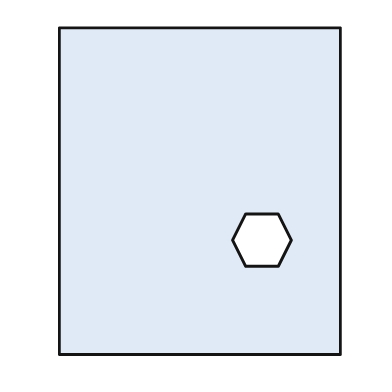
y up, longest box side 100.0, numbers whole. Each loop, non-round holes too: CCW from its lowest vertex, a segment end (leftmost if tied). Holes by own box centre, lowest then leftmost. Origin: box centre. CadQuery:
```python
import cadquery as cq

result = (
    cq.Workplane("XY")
    .moveTo(-43.0, -50.0)
    .lineTo(43.0, -50.0)
    .lineTo(43.0, 50.0)
    .lineTo(-43.0, 50.0)
    .close()
    .moveTo(14.0, -23.0)
    .lineTo(24.0, -23.0)
    .lineTo(28.0, -15.0)
    .lineTo(24.0, -7.0)
    .lineTo(14.0, -7.0)
    .lineTo(10.0, -15.0)
    .close()
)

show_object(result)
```